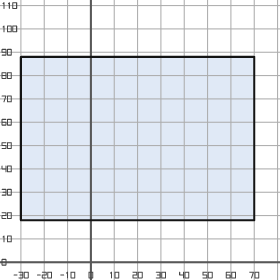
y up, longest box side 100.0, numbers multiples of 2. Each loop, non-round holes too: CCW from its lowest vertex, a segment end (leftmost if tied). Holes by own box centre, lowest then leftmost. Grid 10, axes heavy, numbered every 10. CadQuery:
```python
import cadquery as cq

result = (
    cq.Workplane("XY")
    .moveTo(-30.0, 18.0)
    .lineTo(70.0, 18.0)
    .lineTo(70.0, 88.0)
    .lineTo(-30.0, 88.0)
    .close()
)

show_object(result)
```